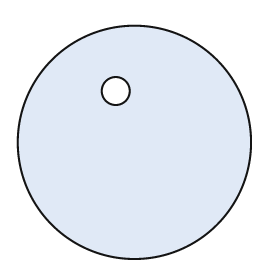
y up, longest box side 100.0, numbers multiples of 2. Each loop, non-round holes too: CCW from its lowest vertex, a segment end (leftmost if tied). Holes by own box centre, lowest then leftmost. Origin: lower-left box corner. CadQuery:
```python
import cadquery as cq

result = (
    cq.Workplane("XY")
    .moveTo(50.0, 50.0)
    .circle(50.0)
    .moveTo(42.0, 72.0)
    .circle(6.0)
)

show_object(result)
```